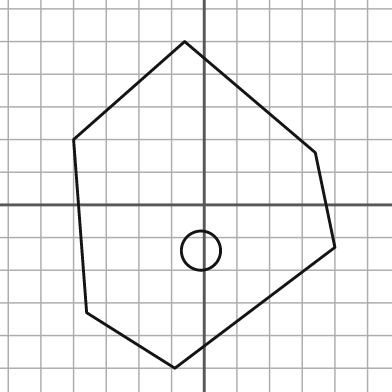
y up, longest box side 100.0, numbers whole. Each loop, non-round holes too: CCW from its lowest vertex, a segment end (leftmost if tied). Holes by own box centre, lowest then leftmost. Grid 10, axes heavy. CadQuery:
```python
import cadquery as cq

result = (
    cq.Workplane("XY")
    .moveTo(-9.0, -50.0)
    .lineTo(40.0, -13.0)
    .lineTo(34.0, 16.0)
    .lineTo(-6.0, 50.0)
    .lineTo(-40.0, 20.0)
    .lineTo(-36.0, -33.0)
    .close()
    .moveTo(-1.0, -14.0)
    .circle(6.0)
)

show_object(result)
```